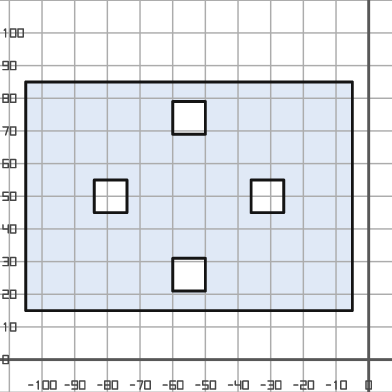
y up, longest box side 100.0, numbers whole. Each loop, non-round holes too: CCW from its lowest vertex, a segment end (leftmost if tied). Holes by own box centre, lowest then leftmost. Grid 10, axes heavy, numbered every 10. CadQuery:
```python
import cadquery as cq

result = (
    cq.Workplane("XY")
    .moveTo(-105.0, 15.0)
    .lineTo(-5.0, 15.0)
    .lineTo(-5.0, 85.0)
    .lineTo(-105.0, 85.0)
    .close()
    .moveTo(-60.0, 21.0)
    .lineTo(-50.0, 21.0)
    .lineTo(-50.0, 31.0)
    .lineTo(-60.0, 31.0)
    .close()
    .moveTo(-84.0, 45.0)
    .lineTo(-74.0, 45.0)
    .lineTo(-74.0, 55.0)
    .lineTo(-84.0, 55.0)
    .close()
    .moveTo(-36.0, 45.0)
    .lineTo(-26.0, 45.0)
    .lineTo(-26.0, 55.0)
    .lineTo(-36.0, 55.0)
    .close()
    .moveTo(-60.0, 69.0)
    .lineTo(-50.0, 69.0)
    .lineTo(-50.0, 79.0)
    .lineTo(-60.0, 79.0)
    .close()
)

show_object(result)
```